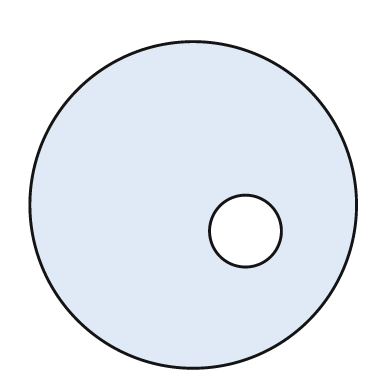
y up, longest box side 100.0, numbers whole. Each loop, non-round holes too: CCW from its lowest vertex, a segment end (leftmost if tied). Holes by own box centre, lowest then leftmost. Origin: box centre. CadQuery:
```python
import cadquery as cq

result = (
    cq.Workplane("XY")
    .moveTo(0.0, 0.0)
    .circle(50.0)
    .moveTo(16.0, -8.0)
    .circle(11.0)
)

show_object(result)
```